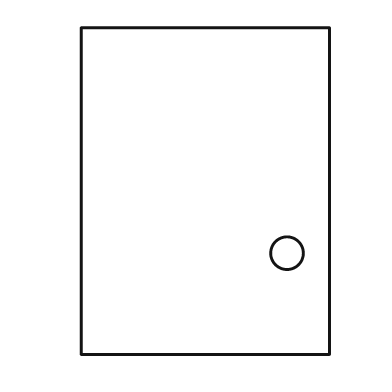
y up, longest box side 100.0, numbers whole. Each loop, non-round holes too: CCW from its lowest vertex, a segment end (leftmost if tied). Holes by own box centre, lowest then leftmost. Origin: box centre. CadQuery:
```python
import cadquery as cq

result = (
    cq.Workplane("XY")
    .moveTo(-38.0, -50.0)
    .lineTo(38.0, -50.0)
    .lineTo(38.0, 50.0)
    .lineTo(-38.0, 50.0)
    .close()
    .moveTo(25.0, -19.0)
    .circle(5.0)
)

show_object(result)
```